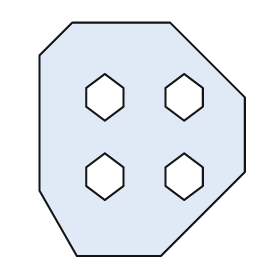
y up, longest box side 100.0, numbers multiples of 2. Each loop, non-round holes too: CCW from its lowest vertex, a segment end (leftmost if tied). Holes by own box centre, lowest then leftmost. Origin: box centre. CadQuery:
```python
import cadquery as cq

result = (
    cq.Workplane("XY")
    .moveTo(-28.0, -50.0)
    .lineTo(8.0, -50.0)
    .lineTo(44.0, -14.0)
    .lineTo(44.0, 18.0)
    .lineTo(12.0, 50.0)
    .lineTo(-30.0, 50.0)
    .lineTo(-44.0, 36.0)
    .lineTo(-44.0, -22.0)
    .close()
    .moveTo(-16.0, -26.0)
    .lineTo(-8.0, -20.0)
    .lineTo(-8.0, -12.0)
    .lineTo(-16.0, -6.0)
    .lineTo(-24.0, -12.0)
    .lineTo(-24.0, -20.0)
    .close()
    .moveTo(18.0, -26.0)
    .lineTo(26.0, -20.0)
    .lineTo(26.0, -12.0)
    .lineTo(18.0, -6.0)
    .lineTo(10.0, -12.0)
    .lineTo(10.0, -20.0)
    .close()
    .moveTo(-16.0, 8.0)
    .lineTo(-8.0, 14.0)
    .lineTo(-8.0, 22.0)
    .lineTo(-16.0, 28.0)
    .lineTo(-24.0, 22.0)
    .lineTo(-24.0, 14.0)
    .close()
    .moveTo(18.0, 8.0)
    .lineTo(26.0, 14.0)
    .lineTo(26.0, 22.0)
    .lineTo(18.0, 28.0)
    .lineTo(10.0, 22.0)
    .lineTo(10.0, 14.0)
    .close()
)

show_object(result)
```